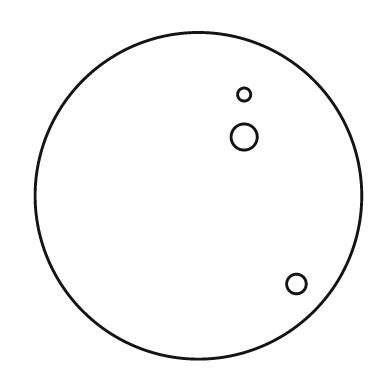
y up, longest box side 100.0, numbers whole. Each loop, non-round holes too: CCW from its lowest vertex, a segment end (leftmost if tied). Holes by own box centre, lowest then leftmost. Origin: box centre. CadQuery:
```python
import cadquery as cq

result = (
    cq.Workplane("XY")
    .moveTo(0.0, 0.0)
    .circle(50.0)
    .moveTo(30.0, -27.0)
    .circle(3.0)
    .moveTo(14.0, 18.0)
    .circle(4.0)
    .moveTo(14.0, 31.0)
    .circle(2.0)
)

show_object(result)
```